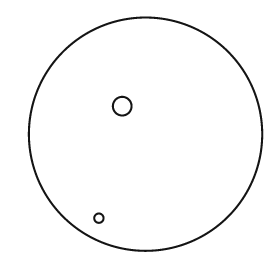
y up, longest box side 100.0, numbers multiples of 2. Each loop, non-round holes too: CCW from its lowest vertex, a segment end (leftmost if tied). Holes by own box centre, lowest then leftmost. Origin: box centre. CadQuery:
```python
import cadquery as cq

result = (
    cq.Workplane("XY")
    .moveTo(0.0, 0.0)
    .circle(50.0)
    .moveTo(-20.0, -36.0)
    .circle(2.0)
    .moveTo(-10.0, 12.0)
    .circle(4.0)
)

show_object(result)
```